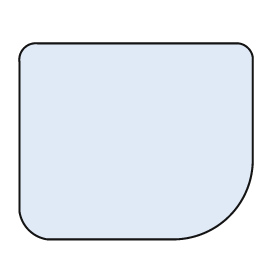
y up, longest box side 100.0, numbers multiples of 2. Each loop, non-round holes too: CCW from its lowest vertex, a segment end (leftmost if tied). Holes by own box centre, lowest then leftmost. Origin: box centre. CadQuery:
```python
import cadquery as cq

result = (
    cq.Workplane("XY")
    .moveTo(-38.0, -42.0)
    .lineTo(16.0, -42.0)
    .threePointArc((40.0, -32.0), (50.0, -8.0))
    .lineTo(50.0, 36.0)
    .threePointArc((48.0, 40.0), (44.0, 42.0))
    .lineTo(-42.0, 42.0)
    .threePointArc((-48.0, 40.0), (-50.0, 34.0))
    .lineTo(-50.0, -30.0)
    .threePointArc((-46.0, -38.0), (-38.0, -42.0))
    .close()
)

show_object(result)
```